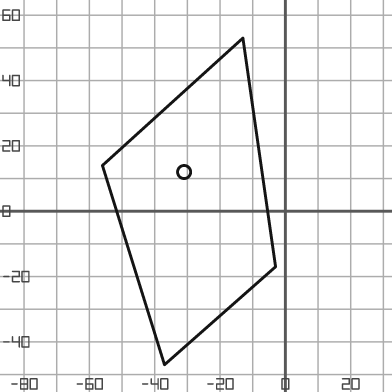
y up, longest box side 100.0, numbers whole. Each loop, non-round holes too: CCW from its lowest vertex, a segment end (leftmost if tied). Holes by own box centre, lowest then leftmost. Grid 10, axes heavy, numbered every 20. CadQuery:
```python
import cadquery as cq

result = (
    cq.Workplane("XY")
    .moveTo(-37.0, -47.0)
    .lineTo(-3.0, -17.0)
    .lineTo(-13.0, 53.0)
    .lineTo(-56.0, 14.0)
    .close()
    .moveTo(-31.0, 12.0)
    .circle(2.0)
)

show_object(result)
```